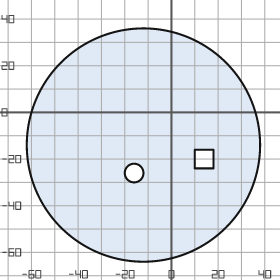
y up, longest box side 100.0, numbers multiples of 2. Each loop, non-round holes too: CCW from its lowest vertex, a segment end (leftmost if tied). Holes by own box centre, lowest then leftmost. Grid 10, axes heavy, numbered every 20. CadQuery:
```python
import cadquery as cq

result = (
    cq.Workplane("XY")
    .moveTo(-12.0, -14.0)
    .circle(50.0)
    .moveTo(-16.0, -26.0)
    .circle(4.0)
    .moveTo(10.0, -24.0)
    .lineTo(18.0, -24.0)
    .lineTo(18.0, -16.0)
    .lineTo(10.0, -16.0)
    .close()
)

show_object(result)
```